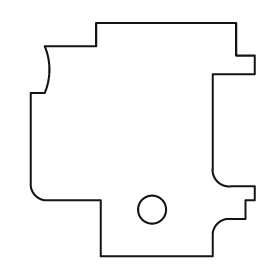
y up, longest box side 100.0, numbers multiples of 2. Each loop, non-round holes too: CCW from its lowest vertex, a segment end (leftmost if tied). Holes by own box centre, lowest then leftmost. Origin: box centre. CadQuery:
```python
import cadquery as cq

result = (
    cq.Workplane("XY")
    .moveTo(-18.0, -50.0)
    .lineTo(30.0, -50.0)
    .lineTo(30.0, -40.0)
    .threePointArc((32.0, -36.0), (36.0, -34.0))
    .lineTo(44.0, -34.0)
    .lineTo(44.0, -26.0)
    .lineTo(48.0, -26.0)
    .lineTo(48.0, -20.0)
    .lineTo(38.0, -20.0)
    .threePointArc((32.0, -18.0), (30.0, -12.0))
    .lineTo(30.0, 28.0)
    .lineTo(48.0, 28.0)
    .lineTo(48.0, 36.0)
    .lineTo(40.0, 36.0)
    .lineTo(40.0, 50.0)
    .lineTo(-20.0, 50.0)
    .lineTo(-20.0, 40.0)
    .lineTo(-42.0, 40.0)
    .threePointArc((-40.0, 30.0), (-42.0, 20.0))
    .lineTo(-48.0, 20.0)
    .lineTo(-48.0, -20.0)
    .threePointArc((-46.0, -24.0), (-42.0, -26.0))
    .lineTo(-18.0, -26.0)
    .close()
    .moveTo(4.0, -30.0)
    .circle(6.0)
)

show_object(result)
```